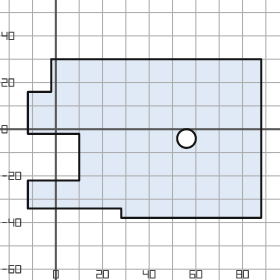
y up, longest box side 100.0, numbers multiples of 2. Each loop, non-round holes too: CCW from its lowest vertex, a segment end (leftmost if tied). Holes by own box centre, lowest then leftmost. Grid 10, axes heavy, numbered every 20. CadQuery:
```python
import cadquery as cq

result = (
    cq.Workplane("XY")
    .moveTo(28.0, -38.0)
    .lineTo(88.0, -38.0)
    .lineTo(88.0, 30.0)
    .lineTo(-2.0, 30.0)
    .lineTo(-2.0, 16.0)
    .lineTo(-12.0, 16.0)
    .lineTo(-12.0, -2.0)
    .lineTo(10.0, -2.0)
    .lineTo(10.0, -22.0)
    .lineTo(-12.0, -22.0)
    .lineTo(-12.0, -34.0)
    .lineTo(28.0, -34.0)
    .close()
    .moveTo(56.0, -4.0)
    .circle(4.0)
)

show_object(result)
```